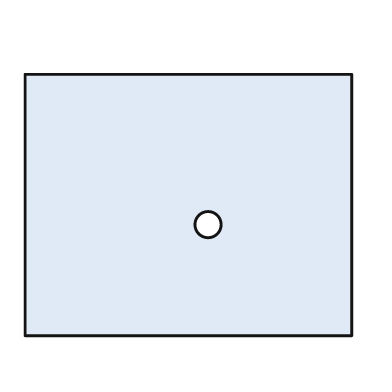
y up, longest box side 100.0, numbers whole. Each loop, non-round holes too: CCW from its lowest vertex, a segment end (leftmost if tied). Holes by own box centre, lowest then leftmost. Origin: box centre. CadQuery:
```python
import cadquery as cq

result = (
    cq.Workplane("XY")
    .moveTo(-50.0, -40.0)
    .lineTo(50.0, -40.0)
    .lineTo(50.0, 40.0)
    .lineTo(-50.0, 40.0)
    .close()
    .moveTo(6.0, -6.0)
    .circle(4.0)
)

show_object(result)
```